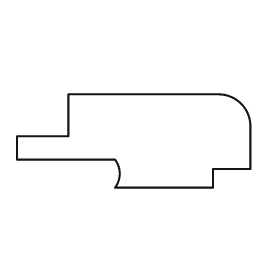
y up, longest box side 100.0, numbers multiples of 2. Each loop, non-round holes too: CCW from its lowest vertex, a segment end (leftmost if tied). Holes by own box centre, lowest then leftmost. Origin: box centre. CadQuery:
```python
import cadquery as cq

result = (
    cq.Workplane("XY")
    .moveTo(-8.0, -20.0)
    .lineTo(34.0, -20.0)
    .lineTo(34.0, -12.0)
    .lineTo(50.0, -12.0)
    .lineTo(50.0, 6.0)
    .threePointArc((46.0, 16.0), (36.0, 20.0))
    .lineTo(-28.0, 20.0)
    .lineTo(-28.0, 2.0)
    .lineTo(-50.0, 2.0)
    .lineTo(-50.0, -8.0)
    .lineTo(-8.0, -8.0)
    .threePointArc((-6.0, -14.0), (-8.0, -20.0))
    .close()
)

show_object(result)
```